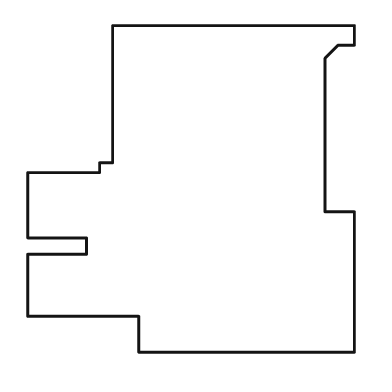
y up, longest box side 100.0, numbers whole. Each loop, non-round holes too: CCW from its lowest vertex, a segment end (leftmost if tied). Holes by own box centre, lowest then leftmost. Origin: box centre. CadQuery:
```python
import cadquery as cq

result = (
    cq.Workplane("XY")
    .moveTo(-16.0, -50.0)
    .lineTo(50.0, -50.0)
    .lineTo(50.0, -7.0)
    .lineTo(41.0, -7.0)
    .lineTo(41.0, 40.0)
    .lineTo(45.0, 44.0)
    .lineTo(50.0, 44.0)
    .lineTo(50.0, 50.0)
    .lineTo(-24.0, 50.0)
    .lineTo(-24.0, 8.0)
    .lineTo(-28.0, 8.0)
    .lineTo(-28.0, 5.0)
    .lineTo(-50.0, 5.0)
    .lineTo(-50.0, -15.0)
    .lineTo(-32.0, -15.0)
    .lineTo(-32.0, -20.0)
    .lineTo(-50.0, -20.0)
    .lineTo(-50.0, -39.0)
    .lineTo(-16.0, -39.0)
    .close()
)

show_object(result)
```